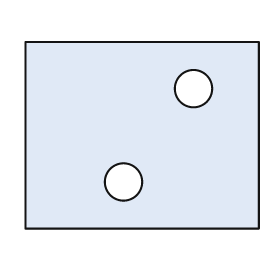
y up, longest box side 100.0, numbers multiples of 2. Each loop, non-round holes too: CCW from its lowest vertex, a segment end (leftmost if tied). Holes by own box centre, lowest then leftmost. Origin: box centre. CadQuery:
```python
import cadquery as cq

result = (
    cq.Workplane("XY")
    .moveTo(-50.0, -40.0)
    .lineTo(50.0, -40.0)
    .lineTo(50.0, 40.0)
    .lineTo(-50.0, 40.0)
    .close()
    .moveTo(-8.0, -20.0)
    .circle(8.0)
    .moveTo(22.0, 20.0)
    .circle(8.0)
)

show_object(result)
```